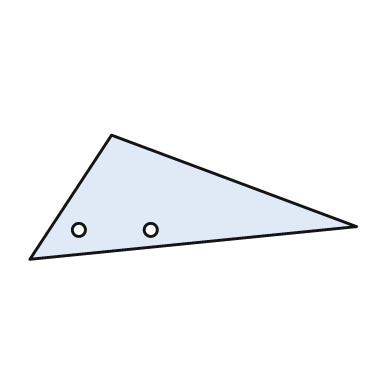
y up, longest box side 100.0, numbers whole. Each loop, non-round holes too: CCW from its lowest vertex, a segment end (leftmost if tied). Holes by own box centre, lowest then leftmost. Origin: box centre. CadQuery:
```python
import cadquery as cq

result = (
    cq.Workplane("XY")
    .moveTo(-50.0, -19.0)
    .lineTo(50.0, -9.0)
    .lineTo(-25.0, 19.0)
    .close()
    .moveTo(-35.0, -10.0)
    .circle(2.0)
    .moveTo(-13.0, -10.0)
    .circle(2.0)
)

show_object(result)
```